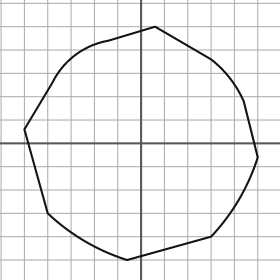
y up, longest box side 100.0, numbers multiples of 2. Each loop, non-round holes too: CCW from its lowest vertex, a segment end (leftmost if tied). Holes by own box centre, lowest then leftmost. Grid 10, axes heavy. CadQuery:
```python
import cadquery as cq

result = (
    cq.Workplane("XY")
    .moveTo(-6.0, -50.0)
    .lineTo(30.0, -40.0)
    .threePointArc((42.0, -24.0), (50.0, -6.0))
    .lineTo(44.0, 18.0)
    .threePointArc((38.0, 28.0), (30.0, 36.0))
    .lineTo(6.0, 50.0)
    .lineTo(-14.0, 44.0)
    .threePointArc((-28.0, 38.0), (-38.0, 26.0))
    .lineTo(-50.0, 6.0)
    .lineTo(-40.0, -30.0)
    .threePointArc((-24.0, -42.0), (-6.0, -50.0))
    .close()
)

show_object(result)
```